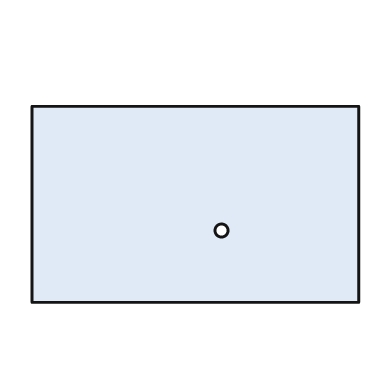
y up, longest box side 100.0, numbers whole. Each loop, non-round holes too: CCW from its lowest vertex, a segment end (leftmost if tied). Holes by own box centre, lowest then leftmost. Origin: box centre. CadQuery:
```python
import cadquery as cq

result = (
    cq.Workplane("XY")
    .moveTo(-50.0, -30.0)
    .lineTo(50.0, -30.0)
    .lineTo(50.0, 30.0)
    .lineTo(-50.0, 30.0)
    .close()
    .moveTo(8.0, -8.0)
    .circle(2.0)
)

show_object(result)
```